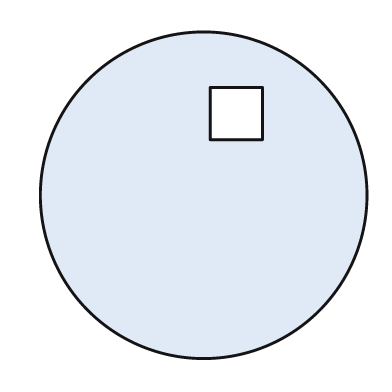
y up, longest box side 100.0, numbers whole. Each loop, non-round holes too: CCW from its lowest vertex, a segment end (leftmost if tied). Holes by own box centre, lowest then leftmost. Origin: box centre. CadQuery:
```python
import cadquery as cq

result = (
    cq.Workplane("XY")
    .moveTo(0.0, 0.0)
    .circle(50.0)
    .moveTo(2.0, 17.0)
    .lineTo(18.0, 17.0)
    .lineTo(18.0, 33.0)
    .lineTo(2.0, 33.0)
    .close()
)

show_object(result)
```